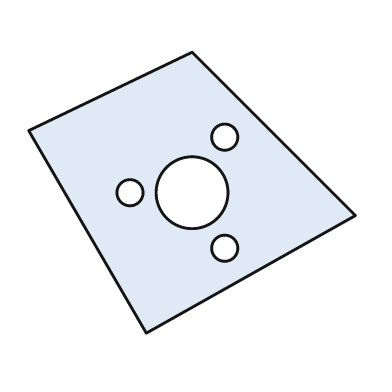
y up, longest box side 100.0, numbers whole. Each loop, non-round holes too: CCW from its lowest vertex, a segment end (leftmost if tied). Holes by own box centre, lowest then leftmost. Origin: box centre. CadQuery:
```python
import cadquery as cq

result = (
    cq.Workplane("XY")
    .moveTo(-14.0, -43.0)
    .lineTo(50.0, -7.0)
    .lineTo(0.0, 43.0)
    .lineTo(-50.0, 19.0)
    .close()
    .moveTo(10.0, -17.0)
    .circle(4.0)
    .moveTo(-19.0, 0.0)
    .circle(4.0)
    .moveTo(0.0, 0.0)
    .circle(11.0)
    .moveTo(10.0, 17.0)
    .circle(4.0)
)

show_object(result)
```